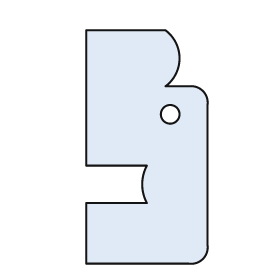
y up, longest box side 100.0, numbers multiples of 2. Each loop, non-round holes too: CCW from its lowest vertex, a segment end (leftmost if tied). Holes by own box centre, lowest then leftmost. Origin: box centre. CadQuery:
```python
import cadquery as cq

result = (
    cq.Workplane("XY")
    .moveTo(-26.0, -50.0)
    .lineTo(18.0, -50.0)
    .threePointArc((24.0, -48.0), (26.0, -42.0))
    .lineTo(26.0, 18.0)
    .threePointArc((24.0, 24.0), (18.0, 26.0))
    .lineTo(8.0, 26.0)
    .threePointArc((14.0, 38.0), (8.0, 50.0))
    .lineTo(-26.0, 50.0)
    .lineTo(-26.0, -8.0)
    .lineTo(0.0, -8.0)
    .threePointArc((-2.0, -16.0), (0.0, -24.0))
    .lineTo(-26.0, -24.0)
    .close()
    .moveTo(10.0, 14.0)
    .circle(4.0)
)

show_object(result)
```